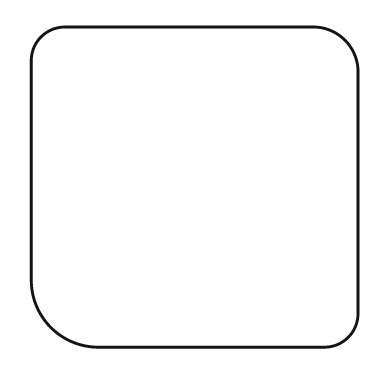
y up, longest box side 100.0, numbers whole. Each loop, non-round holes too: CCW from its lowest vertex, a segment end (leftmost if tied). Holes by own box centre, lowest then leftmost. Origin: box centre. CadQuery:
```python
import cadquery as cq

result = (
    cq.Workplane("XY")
    .moveTo(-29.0, -49.0)
    .lineTo(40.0, -49.0)
    .threePointArc((47.0, -46.0), (50.0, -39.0))
    .lineTo(50.0, 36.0)
    .threePointArc((46.0, 45.0), (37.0, 49.0))
    .lineTo(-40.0, 49.0)
    .threePointArc((-47.0, 46.0), (-50.0, 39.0))
    .lineTo(-50.0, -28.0)
    .threePointArc((-44.0, -43.0), (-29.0, -49.0))
    .close()
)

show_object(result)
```